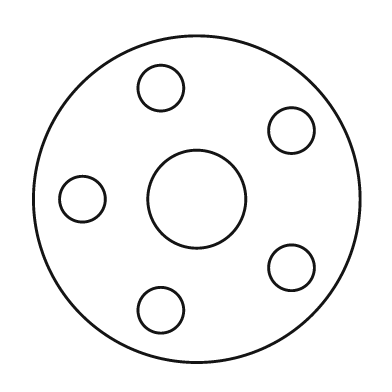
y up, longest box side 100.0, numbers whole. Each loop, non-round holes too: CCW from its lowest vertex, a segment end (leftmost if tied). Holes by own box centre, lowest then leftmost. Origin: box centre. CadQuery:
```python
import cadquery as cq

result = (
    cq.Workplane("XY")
    .moveTo(0.0, 0.0)
    .circle(50.0)
    .moveTo(-11.0, -34.0)
    .circle(7.0)
    .moveTo(29.0, -21.0)
    .circle(7.0)
    .moveTo(-35.0, 0.0)
    .circle(7.0)
    .moveTo(0.0, 0.0)
    .circle(15.0)
    .moveTo(29.0, 21.0)
    .circle(7.0)
    .moveTo(-11.0, 34.0)
    .circle(7.0)
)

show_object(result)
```